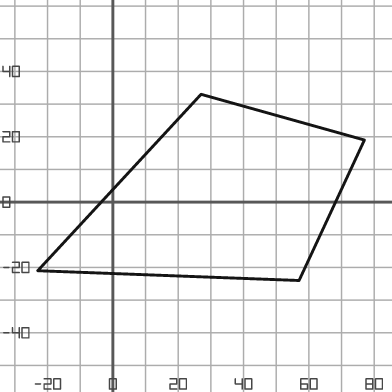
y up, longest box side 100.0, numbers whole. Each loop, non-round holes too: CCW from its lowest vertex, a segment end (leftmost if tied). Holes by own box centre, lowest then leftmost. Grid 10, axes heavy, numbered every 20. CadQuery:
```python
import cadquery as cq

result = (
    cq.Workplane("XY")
    .moveTo(57.0, -24.0)
    .lineTo(77.0, 19.0)
    .lineTo(27.0, 33.0)
    .lineTo(-23.0, -21.0)
    .close()
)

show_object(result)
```